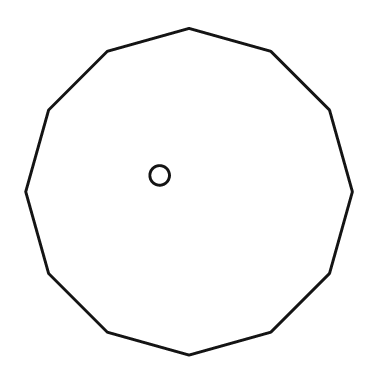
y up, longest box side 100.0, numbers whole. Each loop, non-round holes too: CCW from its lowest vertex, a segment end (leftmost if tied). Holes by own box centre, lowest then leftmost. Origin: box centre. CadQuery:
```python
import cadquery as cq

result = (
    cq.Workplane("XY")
    .moveTo(0.0, -50.0)
    .lineTo(25.0, -43.0)
    .lineTo(43.0, -25.0)
    .lineTo(50.0, 0.0)
    .lineTo(43.0, 25.0)
    .lineTo(25.0, 43.0)
    .lineTo(0.0, 50.0)
    .lineTo(-25.0, 43.0)
    .lineTo(-43.0, 25.0)
    .lineTo(-50.0, 0.0)
    .lineTo(-43.0, -25.0)
    .lineTo(-25.0, -43.0)
    .close()
    .moveTo(-9.0, 5.0)
    .circle(3.0)
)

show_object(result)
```